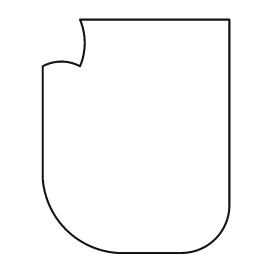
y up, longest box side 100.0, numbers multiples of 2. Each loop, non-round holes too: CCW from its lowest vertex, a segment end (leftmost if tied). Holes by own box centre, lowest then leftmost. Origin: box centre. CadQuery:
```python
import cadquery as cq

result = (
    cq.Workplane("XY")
    .moveTo(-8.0, -50.0)
    .lineTo(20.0, -50.0)
    .threePointArc((34.0, -44.0), (40.0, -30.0))
    .lineTo(40.0, 50.0)
    .lineTo(-24.0, 50.0)
    .threePointArc((-22.0, 40.0), (-24.0, 30.0))
    .threePointArc((-32.0, 32.0), (-40.0, 30.0))
    .lineTo(-40.0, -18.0)
    .threePointArc((-30.0, -40.0), (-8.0, -50.0))
    .close()
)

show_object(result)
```